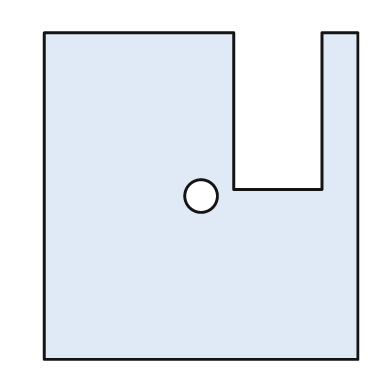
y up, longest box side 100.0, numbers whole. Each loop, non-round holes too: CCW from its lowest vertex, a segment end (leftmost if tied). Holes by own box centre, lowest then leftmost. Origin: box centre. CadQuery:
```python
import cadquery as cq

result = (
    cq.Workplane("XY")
    .moveTo(-48.0, -50.0)
    .lineTo(48.0, -50.0)
    .lineTo(48.0, 50.0)
    .lineTo(37.0, 50.0)
    .lineTo(37.0, 2.0)
    .lineTo(10.0, 2.0)
    .lineTo(10.0, 50.0)
    .lineTo(-48.0, 50.0)
    .close()
    .moveTo(0.0, 0.0)
    .circle(5.0)
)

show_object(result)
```